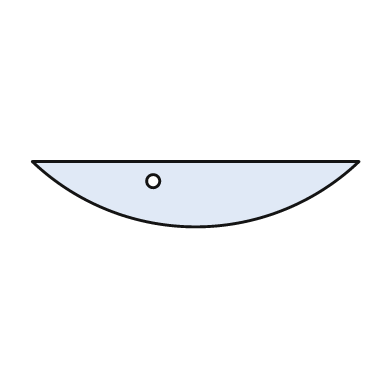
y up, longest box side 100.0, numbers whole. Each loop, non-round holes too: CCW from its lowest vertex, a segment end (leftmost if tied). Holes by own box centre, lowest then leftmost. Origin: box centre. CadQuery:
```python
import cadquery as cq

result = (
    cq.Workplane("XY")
    .moveTo(-50.0, 10.0)
    .threePointArc((0.0, -10.0), (50.0, 10.0))
    .close()
    .moveTo(-13.0, 4.0)
    .circle(2.0)
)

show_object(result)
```